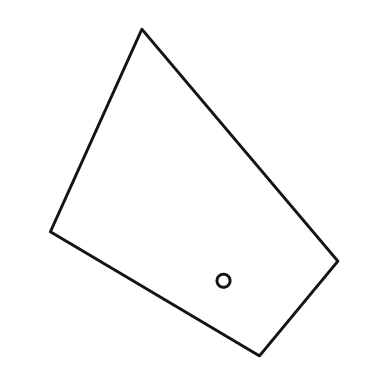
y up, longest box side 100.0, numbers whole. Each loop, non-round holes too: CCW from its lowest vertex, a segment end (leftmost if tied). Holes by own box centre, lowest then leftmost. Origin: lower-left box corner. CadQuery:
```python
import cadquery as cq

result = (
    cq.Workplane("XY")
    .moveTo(64.0, 0.0)
    .lineTo(88.0, 29.0)
    .lineTo(28.0, 100.0)
    .lineTo(0.0, 38.0)
    .close()
    .moveTo(53.0, 23.0)
    .circle(2.0)
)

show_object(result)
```